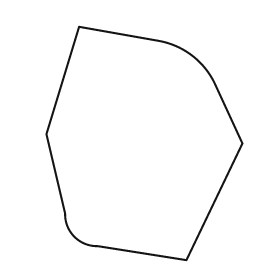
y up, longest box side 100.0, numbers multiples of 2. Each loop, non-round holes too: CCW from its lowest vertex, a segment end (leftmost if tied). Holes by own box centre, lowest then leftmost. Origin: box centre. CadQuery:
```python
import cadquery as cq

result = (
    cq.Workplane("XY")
    .moveTo(18.0, -50.0)
    .lineTo(42.0, 0.0)
    .lineTo(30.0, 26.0)
    .threePointArc((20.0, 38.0), (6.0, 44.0))
    .lineTo(-28.0, 50.0)
    .lineTo(-42.0, 4.0)
    .lineTo(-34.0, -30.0)
    .threePointArc((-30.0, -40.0), (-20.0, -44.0))
    .close()
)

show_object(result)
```